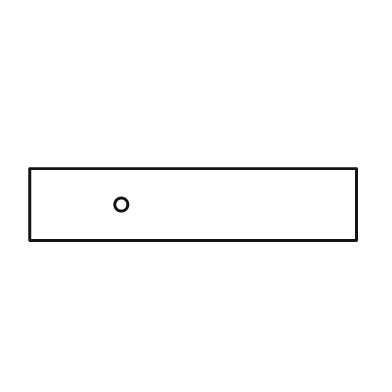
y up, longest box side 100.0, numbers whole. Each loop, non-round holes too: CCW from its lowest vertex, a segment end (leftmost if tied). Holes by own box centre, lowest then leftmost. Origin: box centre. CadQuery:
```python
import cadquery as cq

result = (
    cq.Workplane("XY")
    .moveTo(-50.0, -11.0)
    .lineTo(50.0, -11.0)
    .lineTo(50.0, 11.0)
    .lineTo(-50.0, 11.0)
    .close()
    .moveTo(-22.0, 0.0)
    .circle(2.0)
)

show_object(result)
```